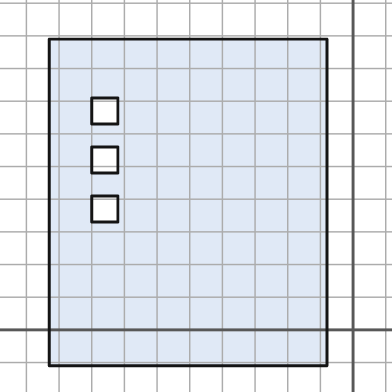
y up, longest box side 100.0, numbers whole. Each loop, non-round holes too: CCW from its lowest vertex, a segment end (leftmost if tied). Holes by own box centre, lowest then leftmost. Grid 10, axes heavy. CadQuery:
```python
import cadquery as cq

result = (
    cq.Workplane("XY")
    .moveTo(-93.0, -11.0)
    .lineTo(-8.0, -11.0)
    .lineTo(-8.0, 89.0)
    .lineTo(-93.0, 89.0)
    .close()
    .moveTo(-80.0, 33.0)
    .lineTo(-72.0, 33.0)
    .lineTo(-72.0, 41.0)
    .lineTo(-80.0, 41.0)
    .close()
    .moveTo(-80.0, 48.0)
    .lineTo(-72.0, 48.0)
    .lineTo(-72.0, 56.0)
    .lineTo(-80.0, 56.0)
    .close()
    .moveTo(-80.0, 63.0)
    .lineTo(-72.0, 63.0)
    .lineTo(-72.0, 71.0)
    .lineTo(-80.0, 71.0)
    .close()
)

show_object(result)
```